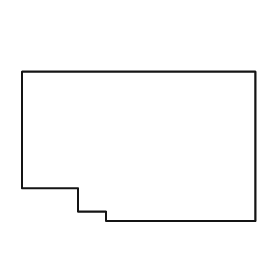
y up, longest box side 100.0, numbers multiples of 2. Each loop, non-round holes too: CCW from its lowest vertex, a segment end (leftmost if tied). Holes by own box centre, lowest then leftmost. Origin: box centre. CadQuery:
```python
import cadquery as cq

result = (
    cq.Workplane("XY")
    .moveTo(-14.0, -32.0)
    .lineTo(50.0, -32.0)
    .lineTo(50.0, 32.0)
    .lineTo(-50.0, 32.0)
    .lineTo(-50.0, -18.0)
    .lineTo(-26.0, -18.0)
    .lineTo(-26.0, -28.0)
    .lineTo(-14.0, -28.0)
    .close()
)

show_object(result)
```